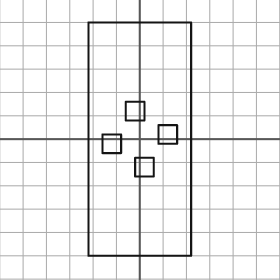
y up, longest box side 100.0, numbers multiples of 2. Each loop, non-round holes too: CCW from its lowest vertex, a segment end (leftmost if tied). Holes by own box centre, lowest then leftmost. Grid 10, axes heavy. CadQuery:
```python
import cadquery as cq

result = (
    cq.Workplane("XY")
    .moveTo(-22.0, -50.0)
    .lineTo(22.0, -50.0)
    .lineTo(22.0, 50.0)
    .lineTo(-22.0, 50.0)
    .close()
    .moveTo(-2.0, -16.0)
    .lineTo(6.0, -16.0)
    .lineTo(6.0, -8.0)
    .lineTo(-2.0, -8.0)
    .close()
    .moveTo(-16.0, -6.0)
    .lineTo(-8.0, -6.0)
    .lineTo(-8.0, 2.0)
    .lineTo(-16.0, 2.0)
    .close()
    .moveTo(8.0, -2.0)
    .lineTo(16.0, -2.0)
    .lineTo(16.0, 6.0)
    .lineTo(8.0, 6.0)
    .close()
    .moveTo(-6.0, 8.0)
    .lineTo(2.0, 8.0)
    .lineTo(2.0, 16.0)
    .lineTo(-6.0, 16.0)
    .close()
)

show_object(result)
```